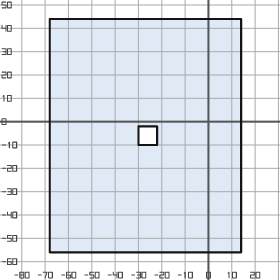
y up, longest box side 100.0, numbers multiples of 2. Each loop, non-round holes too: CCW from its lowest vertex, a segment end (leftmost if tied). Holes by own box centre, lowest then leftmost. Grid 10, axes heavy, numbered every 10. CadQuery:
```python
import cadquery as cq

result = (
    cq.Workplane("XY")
    .moveTo(-68.0, -56.0)
    .lineTo(14.0, -56.0)
    .lineTo(14.0, 44.0)
    .lineTo(-68.0, 44.0)
    .close()
    .moveTo(-30.0, -10.0)
    .lineTo(-22.0, -10.0)
    .lineTo(-22.0, -2.0)
    .lineTo(-30.0, -2.0)
    .close()
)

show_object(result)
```